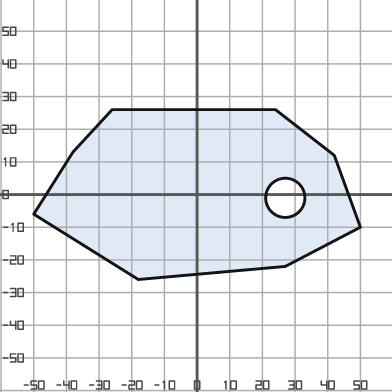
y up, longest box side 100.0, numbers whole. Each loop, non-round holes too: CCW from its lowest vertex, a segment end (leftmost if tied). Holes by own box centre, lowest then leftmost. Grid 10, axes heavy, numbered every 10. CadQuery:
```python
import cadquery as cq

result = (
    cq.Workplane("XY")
    .moveTo(-18.0, -26.0)
    .lineTo(27.0, -22.0)
    .lineTo(50.0, -10.0)
    .lineTo(42.0, 12.0)
    .lineTo(24.0, 26.0)
    .lineTo(-26.0, 26.0)
    .lineTo(-38.0, 13.0)
    .lineTo(-50.0, -6.0)
    .close()
    .moveTo(27.0, -1.0)
    .circle(6.0)
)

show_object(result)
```